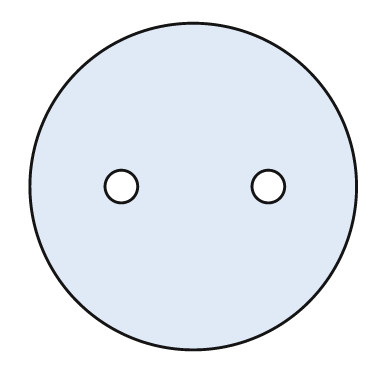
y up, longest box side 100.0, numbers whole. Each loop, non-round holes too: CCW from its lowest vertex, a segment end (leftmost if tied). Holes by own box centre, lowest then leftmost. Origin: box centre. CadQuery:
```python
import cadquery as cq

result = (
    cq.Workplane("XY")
    .moveTo(0.0, 0.0)
    .circle(50.0)
    .moveTo(-22.0, 0.0)
    .circle(5.0)
    .moveTo(23.0, 0.0)
    .circle(5.0)
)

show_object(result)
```